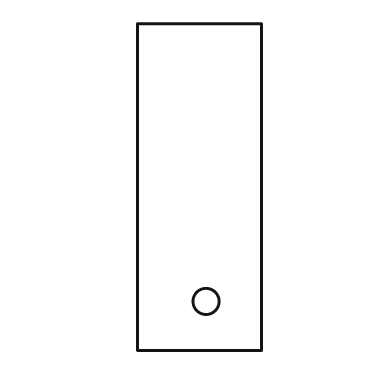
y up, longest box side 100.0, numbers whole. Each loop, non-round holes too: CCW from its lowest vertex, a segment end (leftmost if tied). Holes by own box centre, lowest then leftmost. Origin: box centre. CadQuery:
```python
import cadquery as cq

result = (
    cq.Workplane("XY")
    .moveTo(-19.0, -50.0)
    .lineTo(19.0, -50.0)
    .lineTo(19.0, 50.0)
    .lineTo(-19.0, 50.0)
    .close()
    .moveTo(2.0, -35.0)
    .circle(4.0)
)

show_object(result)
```